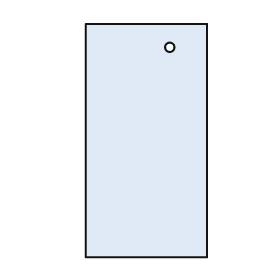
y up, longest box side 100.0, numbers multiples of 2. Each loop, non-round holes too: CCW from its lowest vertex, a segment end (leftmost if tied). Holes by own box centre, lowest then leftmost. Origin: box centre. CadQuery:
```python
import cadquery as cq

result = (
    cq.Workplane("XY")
    .moveTo(-26.0, -50.0)
    .lineTo(26.0, -50.0)
    .lineTo(26.0, 50.0)
    .lineTo(-26.0, 50.0)
    .close()
    .moveTo(10.0, 40.0)
    .circle(2.0)
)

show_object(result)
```